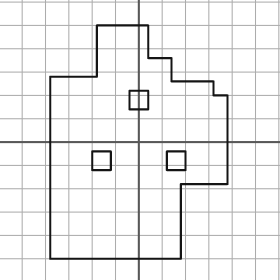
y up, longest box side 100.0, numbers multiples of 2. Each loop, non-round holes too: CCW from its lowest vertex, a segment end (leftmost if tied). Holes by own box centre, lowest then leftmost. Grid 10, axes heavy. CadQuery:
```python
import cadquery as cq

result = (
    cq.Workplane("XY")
    .moveTo(-38.0, -50.0)
    .lineTo(18.0, -50.0)
    .lineTo(18.0, -18.0)
    .lineTo(38.0, -18.0)
    .lineTo(38.0, 20.0)
    .lineTo(32.0, 20.0)
    .lineTo(32.0, 26.0)
    .lineTo(14.0, 26.0)
    .lineTo(14.0, 36.0)
    .lineTo(4.0, 36.0)
    .lineTo(4.0, 50.0)
    .lineTo(-18.0, 50.0)
    .lineTo(-18.0, 28.0)
    .lineTo(-38.0, 28.0)
    .close()
    .moveTo(-20.0, -12.0)
    .lineTo(-12.0, -12.0)
    .lineTo(-12.0, -4.0)
    .lineTo(-20.0, -4.0)
    .close()
    .moveTo(12.0, -12.0)
    .lineTo(20.0, -12.0)
    .lineTo(20.0, -4.0)
    .lineTo(12.0, -4.0)
    .close()
    .moveTo(-4.0, 14.0)
    .lineTo(4.0, 14.0)
    .lineTo(4.0, 22.0)
    .lineTo(-4.0, 22.0)
    .close()
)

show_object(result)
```